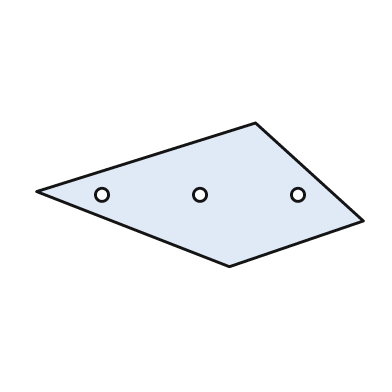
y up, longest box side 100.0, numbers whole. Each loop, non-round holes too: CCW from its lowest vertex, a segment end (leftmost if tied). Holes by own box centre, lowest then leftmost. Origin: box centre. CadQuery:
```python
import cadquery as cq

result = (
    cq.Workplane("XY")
    .moveTo(9.0, -22.0)
    .lineTo(50.0, -8.0)
    .lineTo(17.0, 22.0)
    .lineTo(-50.0, 1.0)
    .close()
    .moveTo(-30.0, 0.0)
    .circle(2.0)
    .moveTo(0.0, 0.0)
    .circle(2.0)
    .moveTo(30.0, 0.0)
    .circle(2.0)
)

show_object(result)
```